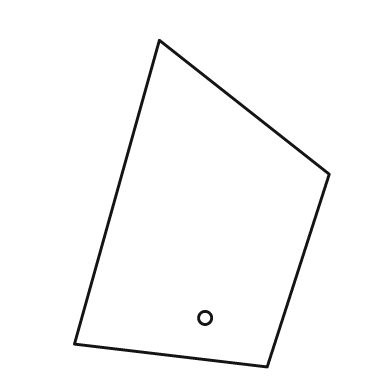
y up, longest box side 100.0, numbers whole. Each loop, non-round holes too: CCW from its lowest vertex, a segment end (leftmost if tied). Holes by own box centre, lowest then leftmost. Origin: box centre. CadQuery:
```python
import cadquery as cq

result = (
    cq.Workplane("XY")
    .moveTo(20.0, -50.0)
    .lineTo(39.0, 9.0)
    .lineTo(-13.0, 50.0)
    .lineTo(-39.0, -43.0)
    .close()
    .moveTo(1.0, -35.0)
    .circle(2.0)
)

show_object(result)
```